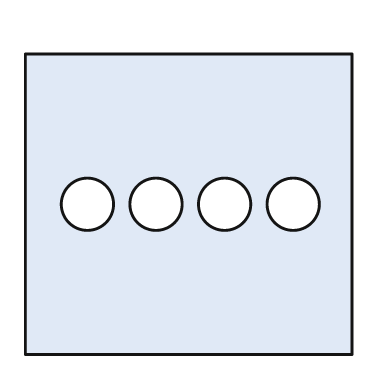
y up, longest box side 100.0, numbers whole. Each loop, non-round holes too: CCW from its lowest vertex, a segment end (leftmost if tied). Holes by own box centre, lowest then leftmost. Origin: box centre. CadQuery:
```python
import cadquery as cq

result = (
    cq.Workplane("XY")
    .moveTo(-50.0, -46.0)
    .lineTo(50.0, -46.0)
    .lineTo(50.0, 46.0)
    .lineTo(-50.0, 46.0)
    .close()
    .moveTo(-31.0, 0.0)
    .circle(8.0)
    .moveTo(-10.0, 0.0)
    .circle(8.0)
    .moveTo(11.0, 0.0)
    .circle(8.0)
    .moveTo(32.0, 0.0)
    .circle(8.0)
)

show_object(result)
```